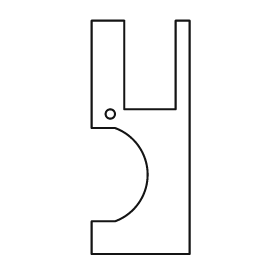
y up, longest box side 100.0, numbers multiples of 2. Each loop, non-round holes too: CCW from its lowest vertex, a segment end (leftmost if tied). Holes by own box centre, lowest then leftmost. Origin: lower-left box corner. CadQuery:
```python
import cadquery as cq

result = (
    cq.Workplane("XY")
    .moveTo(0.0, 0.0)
    .lineTo(42.0, 0.0)
    .lineTo(42.0, 100.0)
    .lineTo(36.0, 100.0)
    .lineTo(36.0, 62.0)
    .lineTo(14.0, 62.0)
    .lineTo(14.0, 100.0)
    .lineTo(0.0, 100.0)
    .lineTo(0.0, 54.0)
    .lineTo(10.0, 54.0)
    .threePointArc((24.0, 34.0), (10.0, 14.0))
    .lineTo(0.0, 14.0)
    .close()
    .moveTo(8.0, 60.0)
    .circle(2.0)
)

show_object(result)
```